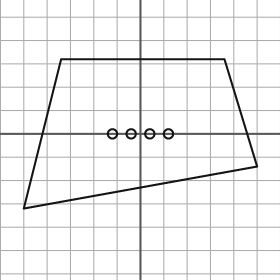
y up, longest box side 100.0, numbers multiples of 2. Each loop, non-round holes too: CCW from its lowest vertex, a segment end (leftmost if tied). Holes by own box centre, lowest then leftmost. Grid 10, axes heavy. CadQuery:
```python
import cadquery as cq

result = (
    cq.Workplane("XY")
    .moveTo(-50.0, -32.0)
    .lineTo(50.0, -14.0)
    .lineTo(36.0, 32.0)
    .lineTo(-34.0, 32.0)
    .close()
    .moveTo(-12.0, 0.0)
    .circle(2.0)
    .moveTo(-4.0, 0.0)
    .circle(2.0)
    .moveTo(4.0, 0.0)
    .circle(2.0)
    .moveTo(12.0, 0.0)
    .circle(2.0)
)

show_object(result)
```